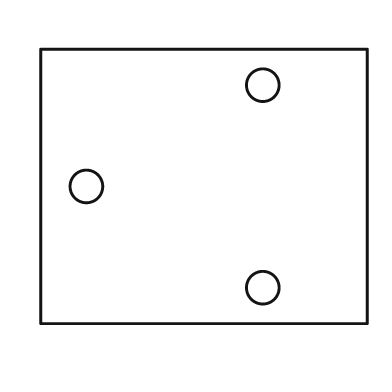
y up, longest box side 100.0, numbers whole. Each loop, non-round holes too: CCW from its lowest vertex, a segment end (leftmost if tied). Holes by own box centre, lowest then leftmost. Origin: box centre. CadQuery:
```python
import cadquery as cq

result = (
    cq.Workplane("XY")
    .moveTo(-50.0, -42.0)
    .lineTo(50.0, -42.0)
    .lineTo(50.0, 42.0)
    .lineTo(-50.0, 42.0)
    .close()
    .moveTo(18.0, -31.0)
    .circle(5.0)
    .moveTo(-36.0, 0.0)
    .circle(5.0)
    .moveTo(18.0, 31.0)
    .circle(5.0)
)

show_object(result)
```